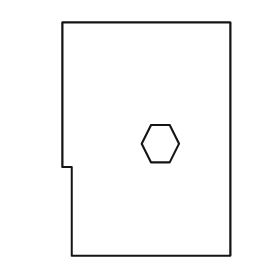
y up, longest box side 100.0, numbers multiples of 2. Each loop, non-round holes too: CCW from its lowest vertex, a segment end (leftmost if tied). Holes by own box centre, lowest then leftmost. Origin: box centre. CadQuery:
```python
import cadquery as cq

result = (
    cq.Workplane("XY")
    .moveTo(-32.0, -50.0)
    .lineTo(36.0, -50.0)
    .lineTo(36.0, 50.0)
    .lineTo(-36.0, 50.0)
    .lineTo(-36.0, -12.0)
    .lineTo(-32.0, -12.0)
    .close()
    .moveTo(2.0, -10.0)
    .lineTo(10.0, -10.0)
    .lineTo(14.0, -2.0)
    .lineTo(10.0, 6.0)
    .lineTo(2.0, 6.0)
    .lineTo(-2.0, -2.0)
    .close()
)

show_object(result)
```